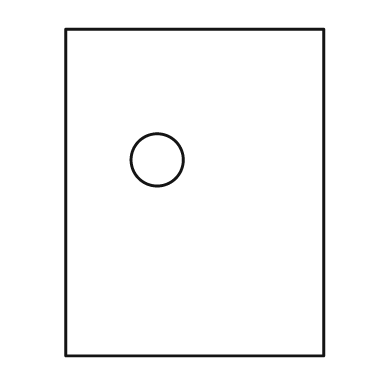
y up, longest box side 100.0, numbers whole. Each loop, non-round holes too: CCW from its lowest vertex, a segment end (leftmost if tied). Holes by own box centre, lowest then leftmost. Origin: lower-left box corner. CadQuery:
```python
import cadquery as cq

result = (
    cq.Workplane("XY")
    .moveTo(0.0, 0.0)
    .lineTo(79.0, 0.0)
    .lineTo(79.0, 100.0)
    .lineTo(0.0, 100.0)
    .close()
    .moveTo(28.0, 60.0)
    .circle(8.0)
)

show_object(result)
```